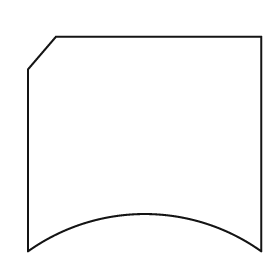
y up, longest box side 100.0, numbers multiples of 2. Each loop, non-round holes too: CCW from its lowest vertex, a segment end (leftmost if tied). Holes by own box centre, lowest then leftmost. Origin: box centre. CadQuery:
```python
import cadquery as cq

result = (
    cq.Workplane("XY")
    .moveTo(-50.0, -46.0)
    .threePointArc((0.0, -30.0), (50.0, -46.0))
    .lineTo(50.0, 46.0)
    .lineTo(-38.0, 46.0)
    .lineTo(-50.0, 32.0)
    .close()
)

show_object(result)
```